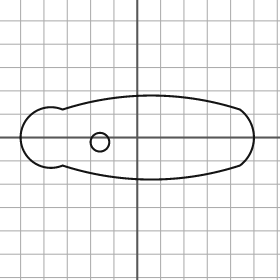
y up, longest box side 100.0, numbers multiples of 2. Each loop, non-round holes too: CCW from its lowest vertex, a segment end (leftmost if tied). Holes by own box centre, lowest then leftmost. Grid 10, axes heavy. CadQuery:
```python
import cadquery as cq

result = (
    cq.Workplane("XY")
    .moveTo(-32.0, -12.0)
    .threePointArc((6.0, -18.0), (44.0, -12.0))
    .threePointArc((50.0, 0.0), (44.0, 12.0))
    .threePointArc((6.0, 18.0), (-32.0, 12.0))
    .threePointArc((-50.0, 0.0), (-32.0, -12.0))
    .close()
    .moveTo(-16.0, -2.0)
    .circle(4.0)
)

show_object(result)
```